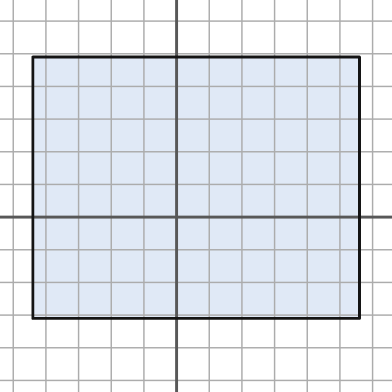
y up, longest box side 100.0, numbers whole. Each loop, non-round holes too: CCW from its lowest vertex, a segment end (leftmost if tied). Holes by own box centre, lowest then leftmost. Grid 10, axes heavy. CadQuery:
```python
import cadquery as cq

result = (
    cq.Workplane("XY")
    .moveTo(-44.0, -31.0)
    .lineTo(56.0, -31.0)
    .lineTo(56.0, 49.0)
    .lineTo(-44.0, 49.0)
    .close()
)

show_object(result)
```